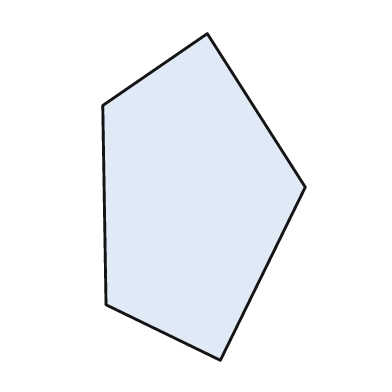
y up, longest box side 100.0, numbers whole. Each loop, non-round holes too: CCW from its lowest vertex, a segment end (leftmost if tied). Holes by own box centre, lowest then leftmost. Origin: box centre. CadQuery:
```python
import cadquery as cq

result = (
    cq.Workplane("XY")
    .moveTo(5.0, -50.0)
    .lineTo(31.0, 3.0)
    .lineTo(1.0, 50.0)
    .lineTo(-31.0, 28.0)
    .lineTo(-30.0, -33.0)
    .close()
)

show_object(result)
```